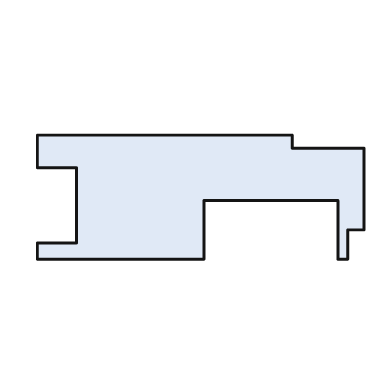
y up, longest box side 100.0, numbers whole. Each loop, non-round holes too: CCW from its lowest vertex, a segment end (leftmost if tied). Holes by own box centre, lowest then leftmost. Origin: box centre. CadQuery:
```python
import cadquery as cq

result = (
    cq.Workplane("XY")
    .moveTo(-50.0, -19.0)
    .lineTo(1.0, -19.0)
    .lineTo(1.0, -1.0)
    .lineTo(42.0, -1.0)
    .lineTo(42.0, -19.0)
    .lineTo(45.0, -19.0)
    .lineTo(45.0, -10.0)
    .lineTo(50.0, -10.0)
    .lineTo(50.0, 15.0)
    .lineTo(28.0, 15.0)
    .lineTo(28.0, 19.0)
    .lineTo(-50.0, 19.0)
    .lineTo(-50.0, 9.0)
    .lineTo(-38.0, 9.0)
    .lineTo(-38.0, -14.0)
    .lineTo(-50.0, -14.0)
    .close()
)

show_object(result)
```